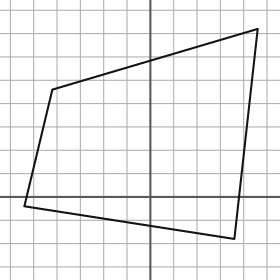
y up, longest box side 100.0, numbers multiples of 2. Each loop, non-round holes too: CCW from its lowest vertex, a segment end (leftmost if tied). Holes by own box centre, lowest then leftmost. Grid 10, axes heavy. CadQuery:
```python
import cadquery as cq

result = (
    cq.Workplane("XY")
    .moveTo(36.0, -18.0)
    .lineTo(46.0, 72.0)
    .lineTo(-42.0, 46.0)
    .lineTo(-54.0, -4.0)
    .close()
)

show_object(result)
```